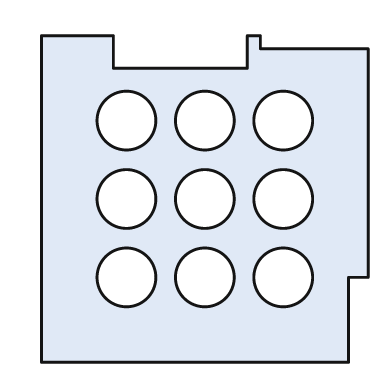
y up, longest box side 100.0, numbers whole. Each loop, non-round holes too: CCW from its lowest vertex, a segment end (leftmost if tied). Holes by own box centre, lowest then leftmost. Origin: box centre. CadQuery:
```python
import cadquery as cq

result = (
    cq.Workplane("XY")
    .moveTo(-50.0, -50.0)
    .lineTo(44.0, -50.0)
    .lineTo(44.0, -24.0)
    .lineTo(50.0, -24.0)
    .lineTo(50.0, 46.0)
    .lineTo(17.0, 46.0)
    .lineTo(17.0, 50.0)
    .lineTo(13.0, 50.0)
    .lineTo(13.0, 40.0)
    .lineTo(-28.0, 40.0)
    .lineTo(-28.0, 50.0)
    .lineTo(-50.0, 50.0)
    .close()
    .moveTo(-24.0, -24.0)
    .circle(9.0)
    .moveTo(0.0, -24.0)
    .circle(9.0)
    .moveTo(24.0, -24.0)
    .circle(9.0)
    .moveTo(-24.0, 0.0)
    .circle(9.0)
    .moveTo(0.0, 0.0)
    .circle(9.0)
    .moveTo(24.0, 0.0)
    .circle(9.0)
    .moveTo(-24.0, 24.0)
    .circle(9.0)
    .moveTo(0.0, 24.0)
    .circle(9.0)
    .moveTo(24.0, 24.0)
    .circle(9.0)
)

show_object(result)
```